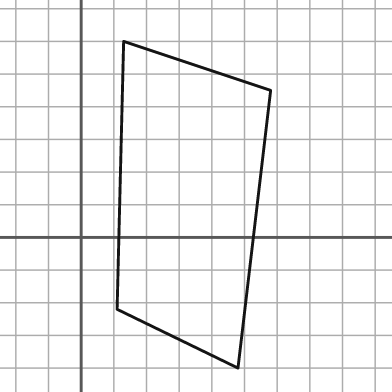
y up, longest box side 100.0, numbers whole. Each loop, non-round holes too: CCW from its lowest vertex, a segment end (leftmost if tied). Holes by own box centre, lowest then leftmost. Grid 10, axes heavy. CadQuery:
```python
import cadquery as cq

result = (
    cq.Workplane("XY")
    .moveTo(48.0, -40.0)
    .lineTo(58.0, 45.0)
    .lineTo(13.0, 60.0)
    .lineTo(11.0, -22.0)
    .close()
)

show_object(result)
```